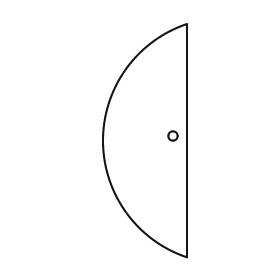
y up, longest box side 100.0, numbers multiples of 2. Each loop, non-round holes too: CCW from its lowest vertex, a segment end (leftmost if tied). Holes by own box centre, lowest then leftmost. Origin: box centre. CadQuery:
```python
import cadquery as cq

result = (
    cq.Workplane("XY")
    .moveTo(18.0, -50.0)
    .lineTo(18.0, 50.0)
    .threePointArc((-18.0, 0.0), (18.0, -50.0))
    .close()
    .moveTo(12.0, 2.0)
    .circle(2.0)
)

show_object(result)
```